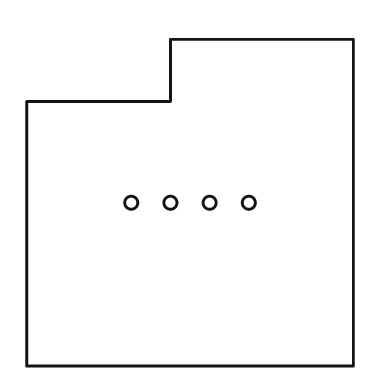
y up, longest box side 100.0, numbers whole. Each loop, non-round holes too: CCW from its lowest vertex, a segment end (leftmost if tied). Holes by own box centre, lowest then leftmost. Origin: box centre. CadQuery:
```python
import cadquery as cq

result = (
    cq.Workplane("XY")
    .moveTo(-50.0, -50.0)
    .lineTo(50.0, -50.0)
    .lineTo(50.0, 50.0)
    .lineTo(-6.0, 50.0)
    .lineTo(-6.0, 31.0)
    .lineTo(-50.0, 31.0)
    .close()
    .moveTo(-18.0, 0.0)
    .circle(2.0)
    .moveTo(-6.0, 0.0)
    .circle(2.0)
    .moveTo(6.0, 0.0)
    .circle(2.0)
    .moveTo(18.0, 0.0)
    .circle(2.0)
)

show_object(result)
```